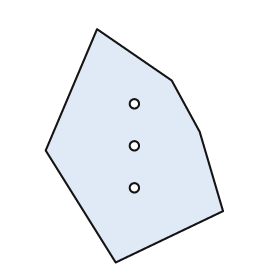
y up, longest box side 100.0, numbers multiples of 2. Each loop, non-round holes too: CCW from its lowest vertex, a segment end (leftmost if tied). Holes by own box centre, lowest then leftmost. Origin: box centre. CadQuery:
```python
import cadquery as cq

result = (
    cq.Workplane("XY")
    .moveTo(-8.0, -50.0)
    .lineTo(38.0, -28.0)
    .lineTo(28.0, 6.0)
    .lineTo(16.0, 28.0)
    .lineTo(-16.0, 50.0)
    .lineTo(-38.0, -2.0)
    .close()
    .moveTo(0.0, -18.0)
    .circle(2.0)
    .moveTo(0.0, 0.0)
    .circle(2.0)
    .moveTo(0.0, 18.0)
    .circle(2.0)
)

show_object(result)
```